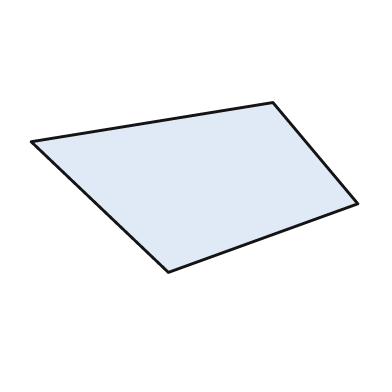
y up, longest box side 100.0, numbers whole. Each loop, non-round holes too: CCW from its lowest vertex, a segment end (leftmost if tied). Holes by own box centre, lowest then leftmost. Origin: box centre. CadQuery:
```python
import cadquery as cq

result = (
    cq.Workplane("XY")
    .moveTo(-8.0, -26.0)
    .lineTo(50.0, -5.0)
    .lineTo(24.0, 26.0)
    .lineTo(-50.0, 14.0)
    .close()
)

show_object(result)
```